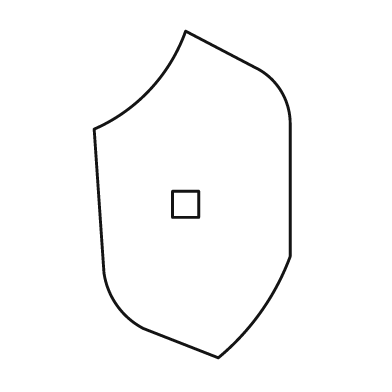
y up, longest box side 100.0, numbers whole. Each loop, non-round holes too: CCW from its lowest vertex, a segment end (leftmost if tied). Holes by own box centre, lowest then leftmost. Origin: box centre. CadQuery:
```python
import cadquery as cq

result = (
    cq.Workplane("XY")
    .moveTo(8.0, -50.0)
    .threePointArc((21.0, -36.0), (30.0, -19.0))
    .lineTo(30.0, 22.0)
    .threePointArc((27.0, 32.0), (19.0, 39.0))
    .lineTo(-2.0, 50.0)
    .threePointArc((-13.0, 32.0), (-30.0, 20.0))
    .lineTo(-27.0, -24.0)
    .threePointArc((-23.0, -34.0), (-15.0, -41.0))
    .close()
    .moveTo(-6.0, -7.0)
    .lineTo(2.0, -7.0)
    .lineTo(2.0, 1.0)
    .lineTo(-6.0, 1.0)
    .close()
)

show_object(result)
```